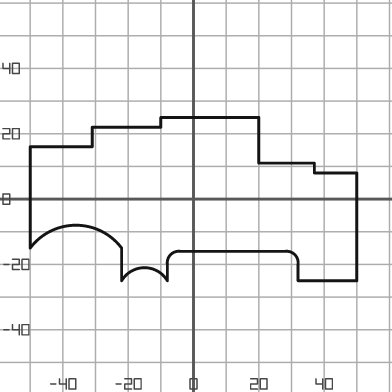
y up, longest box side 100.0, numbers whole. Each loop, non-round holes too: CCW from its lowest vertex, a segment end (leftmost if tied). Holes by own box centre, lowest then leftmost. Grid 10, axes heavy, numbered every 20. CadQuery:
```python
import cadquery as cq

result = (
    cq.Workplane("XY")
    .moveTo(-22.0, -25.0)
    .threePointArc((-15.0, -21.0), (-8.0, -25.0))
    .lineTo(-8.0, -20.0)
    .threePointArc((-7.0, -17.0), (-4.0, -16.0))
    .lineTo(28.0, -16.0)
    .threePointArc((31.0, -17.0), (32.0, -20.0))
    .lineTo(32.0, -25.0)
    .lineTo(50.0, -25.0)
    .lineTo(50.0, 8.0)
    .lineTo(37.0, 8.0)
    .lineTo(37.0, 11.0)
    .lineTo(20.0, 11.0)
    .lineTo(20.0, 25.0)
    .lineTo(-10.0, 25.0)
    .lineTo(-10.0, 22.0)
    .lineTo(-31.0, 22.0)
    .lineTo(-31.0, 16.0)
    .lineTo(-50.0, 16.0)
    .lineTo(-50.0, -15.0)
    .threePointArc((-36.0, -8.0), (-22.0, -15.0))
    .close()
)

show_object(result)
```